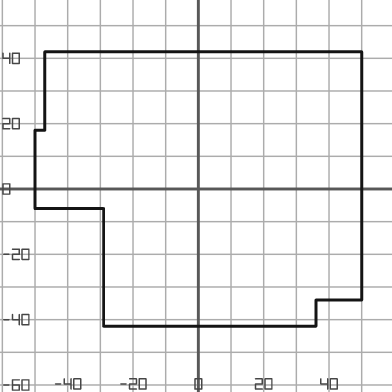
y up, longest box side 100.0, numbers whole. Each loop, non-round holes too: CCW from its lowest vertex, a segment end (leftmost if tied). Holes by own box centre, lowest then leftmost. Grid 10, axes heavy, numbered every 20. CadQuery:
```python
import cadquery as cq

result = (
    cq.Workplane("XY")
    .moveTo(-29.0, -42.0)
    .lineTo(36.0, -42.0)
    .lineTo(36.0, -34.0)
    .lineTo(50.0, -34.0)
    .lineTo(50.0, 42.0)
    .lineTo(-47.0, 42.0)
    .lineTo(-47.0, 18.0)
    .lineTo(-50.0, 18.0)
    .lineTo(-50.0, -6.0)
    .lineTo(-29.0, -6.0)
    .close()
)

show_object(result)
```